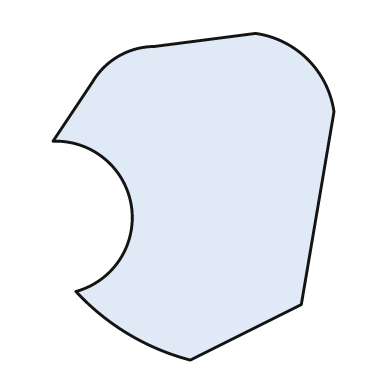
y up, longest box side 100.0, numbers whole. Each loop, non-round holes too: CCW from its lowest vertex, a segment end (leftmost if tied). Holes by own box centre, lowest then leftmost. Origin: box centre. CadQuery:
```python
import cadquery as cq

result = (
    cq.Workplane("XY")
    .moveTo(-1.0, -50.0)
    .lineTo(33.0, -33.0)
    .lineTo(43.0, 26.0)
    .threePointArc((35.0, 42.0), (19.0, 50.0))
    .lineTo(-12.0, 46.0)
    .threePointArc((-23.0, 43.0), (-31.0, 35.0))
    .lineTo(-43.0, 17.0)
    .threePointArc((-19.0, -3.0), (-36.0, -29.0))
    .threePointArc((-20.0, -42.0), (-1.0, -50.0))
    .close()
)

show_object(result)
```